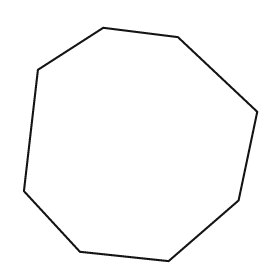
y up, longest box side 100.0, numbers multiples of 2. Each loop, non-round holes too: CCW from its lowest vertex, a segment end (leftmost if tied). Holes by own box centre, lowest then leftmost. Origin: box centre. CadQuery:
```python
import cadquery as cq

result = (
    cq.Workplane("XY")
    .moveTo(12.0, -50.0)
    .lineTo(42.0, -24.0)
    .lineTo(50.0, 14.0)
    .lineTo(16.0, 46.0)
    .lineTo(-16.0, 50.0)
    .lineTo(-44.0, 32.0)
    .lineTo(-50.0, -20.0)
    .lineTo(-26.0, -46.0)
    .close()
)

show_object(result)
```